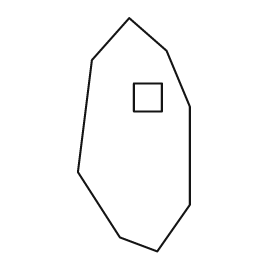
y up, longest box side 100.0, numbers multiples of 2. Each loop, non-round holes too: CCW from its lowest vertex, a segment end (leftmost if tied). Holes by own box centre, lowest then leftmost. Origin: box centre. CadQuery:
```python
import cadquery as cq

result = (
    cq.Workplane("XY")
    .moveTo(10.0, -50.0)
    .lineTo(24.0, -30.0)
    .lineTo(24.0, 12.0)
    .lineTo(14.0, 36.0)
    .lineTo(-2.0, 50.0)
    .lineTo(-18.0, 32.0)
    .lineTo(-24.0, -16.0)
    .lineTo(-6.0, -44.0)
    .close()
    .moveTo(0.0, 10.0)
    .lineTo(12.0, 10.0)
    .lineTo(12.0, 22.0)
    .lineTo(0.0, 22.0)
    .close()
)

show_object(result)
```